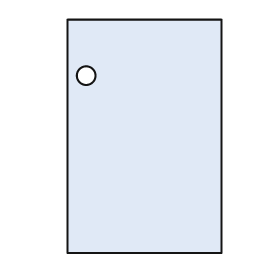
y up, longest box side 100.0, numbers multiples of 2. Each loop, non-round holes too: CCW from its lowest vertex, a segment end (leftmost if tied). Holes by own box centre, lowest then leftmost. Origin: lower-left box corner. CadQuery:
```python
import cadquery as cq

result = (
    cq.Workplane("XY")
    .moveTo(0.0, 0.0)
    .lineTo(66.0, 0.0)
    .lineTo(66.0, 100.0)
    .lineTo(0.0, 100.0)
    .close()
    .moveTo(8.0, 76.0)
    .circle(4.0)
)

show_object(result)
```